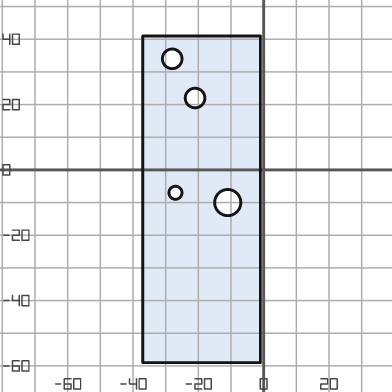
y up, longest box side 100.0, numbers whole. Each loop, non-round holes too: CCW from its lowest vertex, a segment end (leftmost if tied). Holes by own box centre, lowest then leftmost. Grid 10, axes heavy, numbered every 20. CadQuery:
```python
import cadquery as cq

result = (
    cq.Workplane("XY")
    .moveTo(-37.0, -59.0)
    .lineTo(-1.0, -59.0)
    .lineTo(-1.0, 41.0)
    .lineTo(-37.0, 41.0)
    .close()
    .moveTo(-11.0, -10.0)
    .circle(4.0)
    .moveTo(-27.0, -7.0)
    .circle(2.0)
    .moveTo(-21.0, 22.0)
    .circle(3.0)
    .moveTo(-28.0, 34.0)
    .circle(3.0)
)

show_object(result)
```